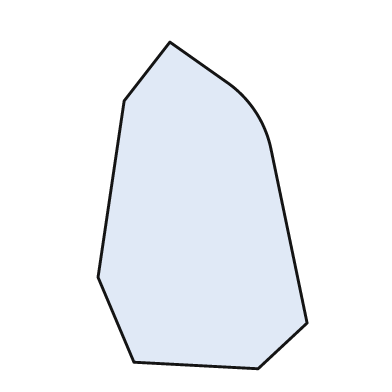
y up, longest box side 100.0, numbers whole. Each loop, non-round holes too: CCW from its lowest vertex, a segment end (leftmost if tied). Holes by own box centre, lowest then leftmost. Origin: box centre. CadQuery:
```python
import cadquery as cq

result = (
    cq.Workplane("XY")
    .moveTo(17.0, -50.0)
    .lineTo(32.0, -36.0)
    .lineTo(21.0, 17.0)
    .threePointArc((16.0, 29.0), (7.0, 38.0))
    .lineTo(-10.0, 50.0)
    .lineTo(-24.0, 32.0)
    .lineTo(-32.0, -22.0)
    .lineTo(-21.0, -48.0)
    .close()
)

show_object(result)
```